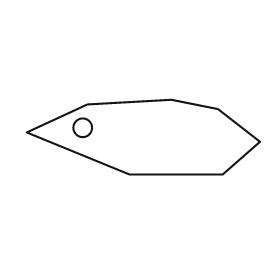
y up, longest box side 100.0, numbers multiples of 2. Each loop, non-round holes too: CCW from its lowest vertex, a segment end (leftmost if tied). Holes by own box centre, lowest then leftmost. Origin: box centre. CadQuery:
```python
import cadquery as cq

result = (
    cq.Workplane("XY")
    .moveTo(-6.0, -16.0)
    .lineTo(34.0, -16.0)
    .lineTo(50.0, -2.0)
    .lineTo(32.0, 12.0)
    .lineTo(12.0, 16.0)
    .lineTo(-24.0, 14.0)
    .lineTo(-50.0, 2.0)
    .close()
    .moveTo(-26.0, 4.0)
    .circle(4.0)
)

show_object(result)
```